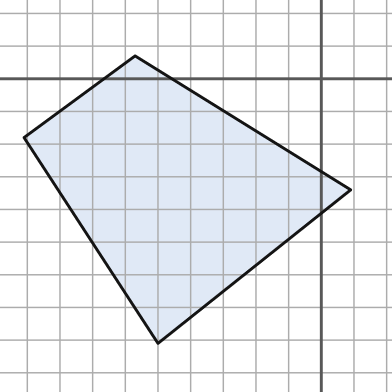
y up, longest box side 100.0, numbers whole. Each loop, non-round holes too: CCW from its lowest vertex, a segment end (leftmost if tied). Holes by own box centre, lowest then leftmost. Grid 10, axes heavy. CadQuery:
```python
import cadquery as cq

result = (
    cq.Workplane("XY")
    .moveTo(-50.0, -81.0)
    .lineTo(9.0, -34.0)
    .lineTo(-57.0, 7.0)
    .lineTo(-91.0, -18.0)
    .close()
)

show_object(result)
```